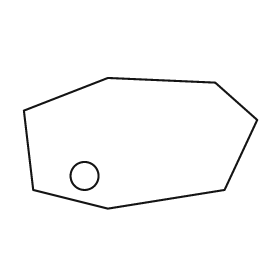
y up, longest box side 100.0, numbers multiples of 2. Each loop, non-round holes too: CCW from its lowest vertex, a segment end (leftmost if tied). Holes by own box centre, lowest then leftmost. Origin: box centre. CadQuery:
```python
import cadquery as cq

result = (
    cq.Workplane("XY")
    .moveTo(-14.0, -28.0)
    .lineTo(36.0, -20.0)
    .lineTo(50.0, 10.0)
    .lineTo(32.0, 26.0)
    .lineTo(-14.0, 28.0)
    .lineTo(-50.0, 14.0)
    .lineTo(-46.0, -20.0)
    .close()
    .moveTo(-24.0, -14.0)
    .circle(6.0)
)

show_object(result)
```